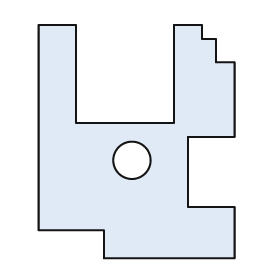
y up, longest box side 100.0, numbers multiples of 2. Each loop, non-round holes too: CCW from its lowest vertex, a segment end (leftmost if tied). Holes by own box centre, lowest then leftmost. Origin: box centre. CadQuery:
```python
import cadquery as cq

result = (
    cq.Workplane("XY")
    .moveTo(-14.0, -50.0)
    .lineTo(42.0, -50.0)
    .lineTo(42.0, -28.0)
    .lineTo(22.0, -28.0)
    .lineTo(22.0, 2.0)
    .lineTo(42.0, 2.0)
    .lineTo(42.0, 34.0)
    .lineTo(34.0, 34.0)
    .lineTo(34.0, 44.0)
    .lineTo(28.0, 44.0)
    .lineTo(28.0, 50.0)
    .lineTo(16.0, 50.0)
    .lineTo(16.0, 8.0)
    .lineTo(-26.0, 8.0)
    .lineTo(-26.0, 50.0)
    .lineTo(-42.0, 50.0)
    .lineTo(-42.0, -38.0)
    .lineTo(-14.0, -38.0)
    .close()
    .moveTo(-2.0, -8.0)
    .circle(8.0)
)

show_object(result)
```